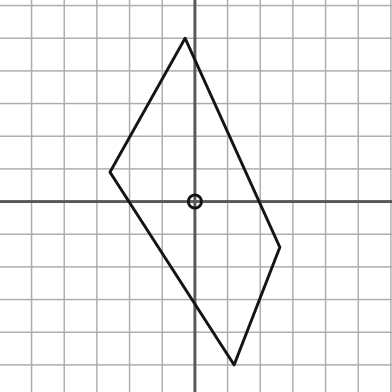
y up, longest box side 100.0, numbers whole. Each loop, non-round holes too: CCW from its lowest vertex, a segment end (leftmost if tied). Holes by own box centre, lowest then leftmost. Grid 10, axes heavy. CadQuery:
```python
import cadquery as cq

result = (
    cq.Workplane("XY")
    .moveTo(12.0, -50.0)
    .lineTo(26.0, -14.0)
    .lineTo(-3.0, 50.0)
    .lineTo(-26.0, 9.0)
    .close()
    .moveTo(0.0, 0.0)
    .circle(2.0)
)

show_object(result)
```